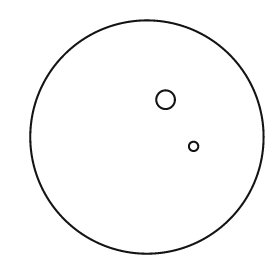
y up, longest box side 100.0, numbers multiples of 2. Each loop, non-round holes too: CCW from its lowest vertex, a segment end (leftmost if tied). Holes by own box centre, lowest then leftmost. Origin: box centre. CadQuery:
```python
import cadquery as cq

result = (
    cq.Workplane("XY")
    .moveTo(0.0, 0.0)
    .circle(50.0)
    .moveTo(20.0, -4.0)
    .circle(2.0)
    .moveTo(8.0, 16.0)
    .circle(4.0)
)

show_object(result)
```